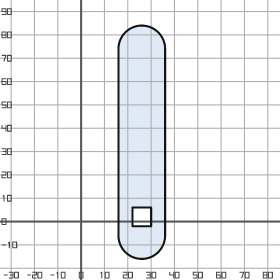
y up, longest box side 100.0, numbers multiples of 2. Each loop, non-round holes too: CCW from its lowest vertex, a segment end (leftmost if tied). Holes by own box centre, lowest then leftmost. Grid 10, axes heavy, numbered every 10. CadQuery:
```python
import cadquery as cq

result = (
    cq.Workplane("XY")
    .moveTo(16.0, -6.0)
    .threePointArc((26.0, -16.0), (36.0, -6.0))
    .lineTo(36.0, 74.0)
    .threePointArc((26.0, 84.0), (16.0, 74.0))
    .close()
    .moveTo(22.0, -2.0)
    .lineTo(30.0, -2.0)
    .lineTo(30.0, 6.0)
    .lineTo(22.0, 6.0)
    .close()
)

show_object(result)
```